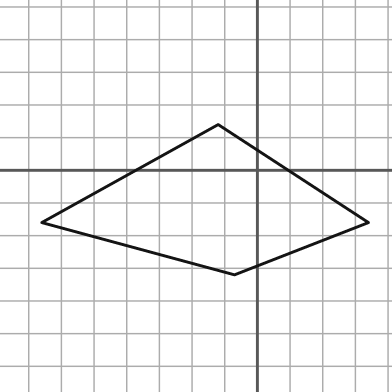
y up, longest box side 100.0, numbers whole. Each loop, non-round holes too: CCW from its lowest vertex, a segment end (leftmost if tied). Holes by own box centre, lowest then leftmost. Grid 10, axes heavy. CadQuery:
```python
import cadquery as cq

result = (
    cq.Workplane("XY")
    .moveTo(-7.0, -32.0)
    .lineTo(34.0, -16.0)
    .lineTo(-12.0, 14.0)
    .lineTo(-66.0, -16.0)
    .close()
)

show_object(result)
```